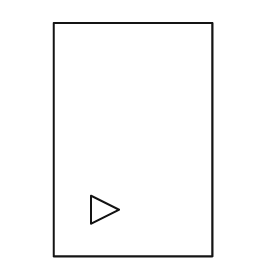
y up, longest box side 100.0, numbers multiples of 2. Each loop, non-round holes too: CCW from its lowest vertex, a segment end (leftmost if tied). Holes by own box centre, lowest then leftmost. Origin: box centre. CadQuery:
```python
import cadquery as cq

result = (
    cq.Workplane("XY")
    .moveTo(-34.0, -50.0)
    .lineTo(34.0, -50.0)
    .lineTo(34.0, 50.0)
    .lineTo(-34.0, 50.0)
    .close()
    .moveTo(-18.0, -36.0)
    .lineTo(-6.0, -30.0)
    .lineTo(-18.0, -24.0)
    .close()
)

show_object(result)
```